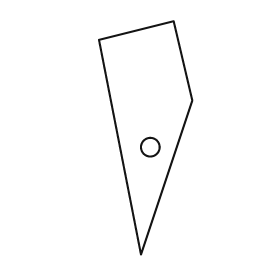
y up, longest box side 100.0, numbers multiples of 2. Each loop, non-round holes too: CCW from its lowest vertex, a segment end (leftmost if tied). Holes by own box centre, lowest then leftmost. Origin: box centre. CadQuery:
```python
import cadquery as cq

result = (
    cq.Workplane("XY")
    .moveTo(-2.0, -50.0)
    .lineTo(20.0, 16.0)
    .lineTo(12.0, 50.0)
    .lineTo(-20.0, 42.0)
    .close()
    .moveTo(2.0, -4.0)
    .circle(4.0)
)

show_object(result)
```